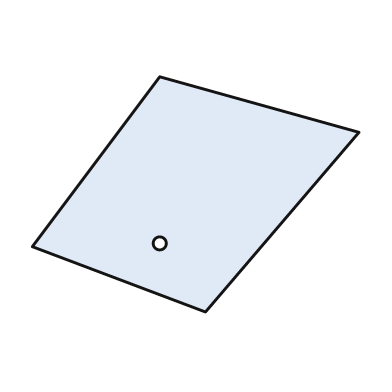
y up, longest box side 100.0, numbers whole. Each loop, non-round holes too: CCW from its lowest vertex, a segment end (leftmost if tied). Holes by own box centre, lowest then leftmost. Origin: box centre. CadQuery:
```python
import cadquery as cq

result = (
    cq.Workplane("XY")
    .moveTo(3.0, -36.0)
    .lineTo(50.0, 19.0)
    .lineTo(-11.0, 36.0)
    .lineTo(-50.0, -16.0)
    .close()
    .moveTo(-11.0, -15.0)
    .circle(2.0)
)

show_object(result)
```